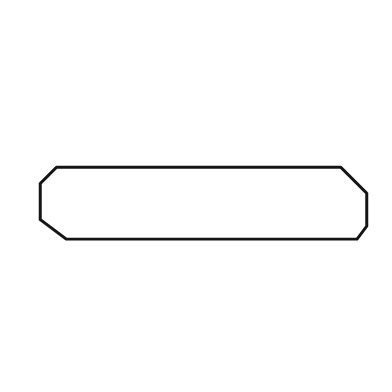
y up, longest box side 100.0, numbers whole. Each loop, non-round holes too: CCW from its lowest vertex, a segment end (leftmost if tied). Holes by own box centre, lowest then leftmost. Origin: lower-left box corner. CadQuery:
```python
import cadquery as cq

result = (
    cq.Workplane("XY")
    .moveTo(8.0, 0.0)
    .lineTo(97.0, 0.0)
    .lineTo(100.0, 4.0)
    .lineTo(100.0, 14.0)
    .lineTo(92.0, 22.0)
    .lineTo(5.0, 22.0)
    .lineTo(0.0, 17.0)
    .lineTo(0.0, 6.0)
    .close()
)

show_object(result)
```